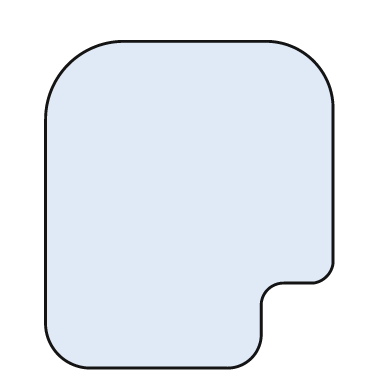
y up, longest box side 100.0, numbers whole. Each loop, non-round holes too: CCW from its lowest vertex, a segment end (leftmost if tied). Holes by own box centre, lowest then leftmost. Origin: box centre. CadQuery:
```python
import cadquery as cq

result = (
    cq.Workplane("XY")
    .moveTo(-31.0, -50.0)
    .lineTo(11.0, -50.0)
    .threePointArc((19.0, -47.0), (22.0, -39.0))
    .lineTo(22.0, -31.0)
    .threePointArc((24.0, -26.0), (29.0, -24.0))
    .lineTo(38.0, -24.0)
    .threePointArc((42.0, -22.0), (44.0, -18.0))
    .lineTo(44.0, 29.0)
    .threePointArc((38.0, 44.0), (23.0, 50.0))
    .lineTo(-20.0, 50.0)
    .threePointArc((-37.0, 43.0), (-44.0, 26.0))
    .lineTo(-44.0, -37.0)
    .threePointArc((-40.0, -46.0), (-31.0, -50.0))
    .close()
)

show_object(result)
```